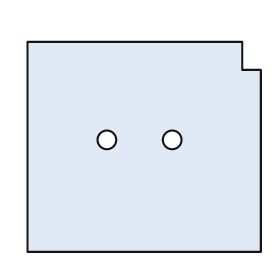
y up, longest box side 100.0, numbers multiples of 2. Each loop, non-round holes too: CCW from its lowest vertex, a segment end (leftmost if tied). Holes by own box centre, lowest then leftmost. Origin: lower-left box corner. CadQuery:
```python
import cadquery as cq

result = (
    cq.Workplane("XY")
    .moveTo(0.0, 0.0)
    .lineTo(100.0, 0.0)
    .lineTo(100.0, 78.0)
    .lineTo(92.0, 78.0)
    .lineTo(92.0, 90.0)
    .lineTo(0.0, 90.0)
    .close()
    .moveTo(34.0, 48.0)
    .circle(4.0)
    .moveTo(62.0, 48.0)
    .circle(4.0)
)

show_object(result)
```